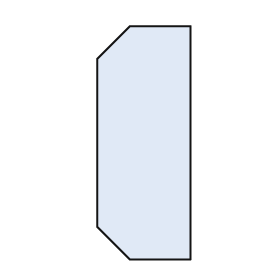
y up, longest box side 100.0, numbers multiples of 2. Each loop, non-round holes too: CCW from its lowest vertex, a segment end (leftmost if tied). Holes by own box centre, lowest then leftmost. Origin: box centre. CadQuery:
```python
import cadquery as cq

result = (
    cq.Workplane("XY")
    .moveTo(-6.0, -50.0)
    .lineTo(20.0, -50.0)
    .lineTo(20.0, 50.0)
    .lineTo(-6.0, 50.0)
    .lineTo(-20.0, 36.0)
    .lineTo(-20.0, -36.0)
    .close()
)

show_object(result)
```